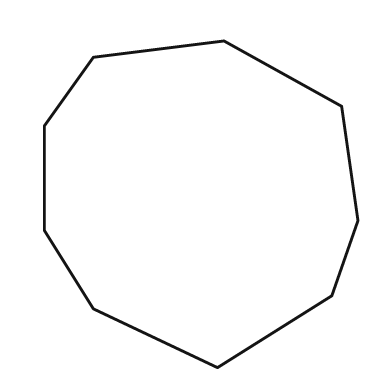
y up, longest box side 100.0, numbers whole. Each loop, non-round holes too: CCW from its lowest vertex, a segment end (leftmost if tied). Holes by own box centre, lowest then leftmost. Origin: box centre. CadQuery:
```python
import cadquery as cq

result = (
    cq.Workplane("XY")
    .moveTo(5.0, -50.0)
    .lineTo(40.0, -28.0)
    .lineTo(48.0, -5.0)
    .lineTo(43.0, 30.0)
    .lineTo(7.0, 50.0)
    .lineTo(-33.0, 45.0)
    .lineTo(-48.0, 24.0)
    .lineTo(-48.0, -8.0)
    .lineTo(-33.0, -32.0)
    .close()
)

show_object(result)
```